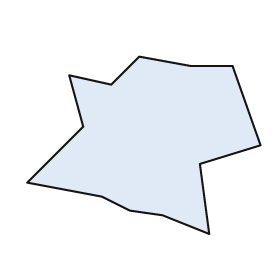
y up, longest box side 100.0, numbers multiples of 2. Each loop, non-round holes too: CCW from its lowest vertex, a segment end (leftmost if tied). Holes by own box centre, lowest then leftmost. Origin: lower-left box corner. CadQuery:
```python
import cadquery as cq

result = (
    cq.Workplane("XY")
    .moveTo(78.0, 0.0)
    .lineTo(74.0, 30.0)
    .lineTo(100.0, 38.0)
    .lineTo(88.0, 72.0)
    .lineTo(70.0, 72.0)
    .lineTo(48.0, 76.0)
    .lineTo(36.0, 64.0)
    .lineTo(18.0, 68.0)
    .lineTo(24.0, 46.0)
    .lineTo(0.0, 22.0)
    .lineTo(32.0, 16.0)
    .lineTo(44.0, 10.0)
    .lineTo(58.0, 8.0)
    .close()
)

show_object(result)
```